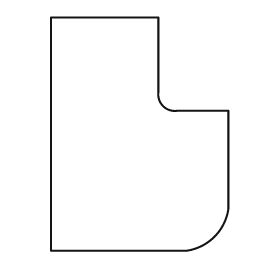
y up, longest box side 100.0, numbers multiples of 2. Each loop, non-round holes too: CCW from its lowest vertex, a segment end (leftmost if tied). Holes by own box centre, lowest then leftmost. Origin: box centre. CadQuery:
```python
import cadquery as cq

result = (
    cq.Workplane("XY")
    .moveTo(-38.0, -50.0)
    .lineTo(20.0, -50.0)
    .threePointArc((32.0, -44.0), (38.0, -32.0))
    .lineTo(38.0, 10.0)
    .lineTo(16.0, 10.0)
    .threePointArc((10.0, 12.0), (8.0, 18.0))
    .lineTo(8.0, 50.0)
    .lineTo(-38.0, 50.0)
    .close()
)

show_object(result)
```